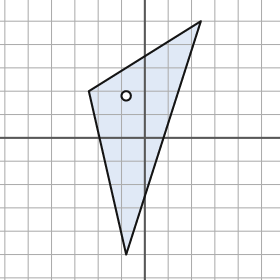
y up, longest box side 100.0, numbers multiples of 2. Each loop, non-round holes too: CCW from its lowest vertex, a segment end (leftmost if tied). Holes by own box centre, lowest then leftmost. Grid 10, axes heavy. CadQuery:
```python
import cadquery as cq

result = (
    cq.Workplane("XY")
    .moveTo(-8.0, -50.0)
    .lineTo(24.0, 50.0)
    .lineTo(-24.0, 20.0)
    .close()
    .moveTo(-8.0, 18.0)
    .circle(2.0)
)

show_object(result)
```